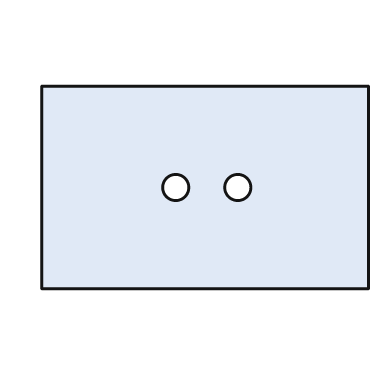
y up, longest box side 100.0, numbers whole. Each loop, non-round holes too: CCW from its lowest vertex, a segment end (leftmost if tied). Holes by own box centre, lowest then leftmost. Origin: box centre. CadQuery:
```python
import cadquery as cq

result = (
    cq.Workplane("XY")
    .moveTo(-50.0, -31.0)
    .lineTo(50.0, -31.0)
    .lineTo(50.0, 31.0)
    .lineTo(-50.0, 31.0)
    .close()
    .moveTo(-9.0, 0.0)
    .circle(4.0)
    .moveTo(10.0, 0.0)
    .circle(4.0)
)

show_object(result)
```